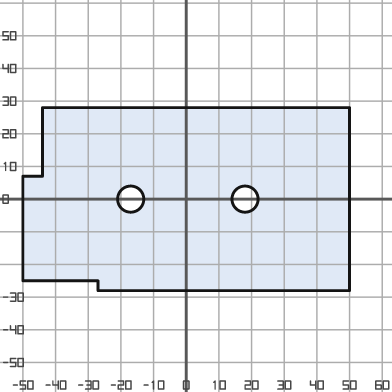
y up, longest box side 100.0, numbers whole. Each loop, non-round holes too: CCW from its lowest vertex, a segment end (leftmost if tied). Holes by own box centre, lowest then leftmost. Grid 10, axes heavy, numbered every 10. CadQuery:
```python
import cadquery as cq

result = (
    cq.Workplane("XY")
    .moveTo(-27.0, -28.0)
    .lineTo(50.0, -28.0)
    .lineTo(50.0, 28.0)
    .lineTo(-44.0, 28.0)
    .lineTo(-44.0, 7.0)
    .lineTo(-50.0, 7.0)
    .lineTo(-50.0, -25.0)
    .lineTo(-27.0, -25.0)
    .close()
    .moveTo(-17.0, 0.0)
    .circle(4.0)
    .moveTo(18.0, 0.0)
    .circle(4.0)
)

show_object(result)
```